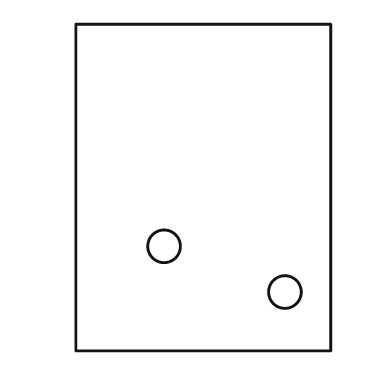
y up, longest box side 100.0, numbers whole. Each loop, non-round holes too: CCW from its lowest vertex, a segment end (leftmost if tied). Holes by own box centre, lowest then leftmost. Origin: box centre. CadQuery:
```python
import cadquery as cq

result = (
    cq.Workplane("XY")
    .moveTo(-39.0, -50.0)
    .lineTo(39.0, -50.0)
    .lineTo(39.0, 50.0)
    .lineTo(-39.0, 50.0)
    .close()
    .moveTo(25.0, -32.0)
    .circle(5.0)
    .moveTo(-12.0, -18.0)
    .circle(5.0)
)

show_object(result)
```